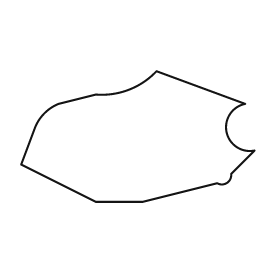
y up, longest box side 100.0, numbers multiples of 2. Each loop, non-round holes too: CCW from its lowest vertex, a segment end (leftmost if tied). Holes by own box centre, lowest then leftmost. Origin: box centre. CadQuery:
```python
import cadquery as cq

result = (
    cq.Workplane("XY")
    .moveTo(-18.0, -28.0)
    .lineTo(2.0, -28.0)
    .lineTo(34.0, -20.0)
    .threePointArc((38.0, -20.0), (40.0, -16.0))
    .lineTo(50.0, -6.0)
    .threePointArc((38.0, 2.0), (46.0, 14.0))
    .lineTo(8.0, 28.0)
    .threePointArc((-4.0, 20.0), (-18.0, 18.0))
    .lineTo(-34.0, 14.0)
    .threePointArc((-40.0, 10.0), (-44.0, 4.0))
    .lineTo(-50.0, -12.0)
    .close()
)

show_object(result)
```